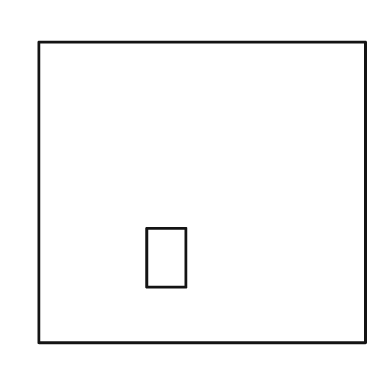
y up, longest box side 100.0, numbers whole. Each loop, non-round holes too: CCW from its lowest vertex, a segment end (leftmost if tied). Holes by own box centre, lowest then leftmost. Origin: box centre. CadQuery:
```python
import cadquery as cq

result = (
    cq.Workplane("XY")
    .moveTo(-50.0, -46.0)
    .lineTo(50.0, -46.0)
    .lineTo(50.0, 46.0)
    .lineTo(-50.0, 46.0)
    .close()
    .moveTo(-17.0, -29.0)
    .lineTo(-5.0, -29.0)
    .lineTo(-5.0, -11.0)
    .lineTo(-17.0, -11.0)
    .close()
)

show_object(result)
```